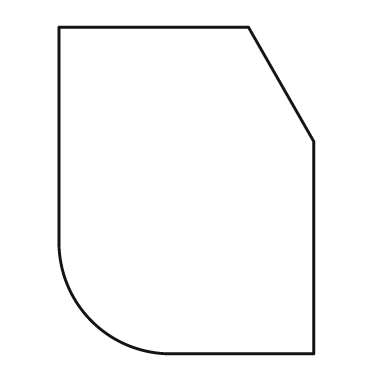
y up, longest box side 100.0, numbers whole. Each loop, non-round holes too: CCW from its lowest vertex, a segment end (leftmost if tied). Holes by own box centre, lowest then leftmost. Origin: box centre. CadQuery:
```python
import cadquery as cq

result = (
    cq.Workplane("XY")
    .moveTo(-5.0, -50.0)
    .lineTo(39.0, -50.0)
    .lineTo(39.0, 15.0)
    .lineTo(19.0, 50.0)
    .lineTo(-39.0, 50.0)
    .lineTo(-39.0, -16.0)
    .threePointArc((-29.0, -40.0), (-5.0, -50.0))
    .close()
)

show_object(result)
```